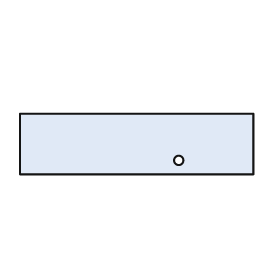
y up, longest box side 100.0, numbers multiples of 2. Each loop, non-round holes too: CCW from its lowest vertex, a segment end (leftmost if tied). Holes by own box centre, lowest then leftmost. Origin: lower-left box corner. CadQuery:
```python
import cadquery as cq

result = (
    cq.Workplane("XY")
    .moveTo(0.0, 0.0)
    .lineTo(100.0, 0.0)
    .lineTo(100.0, 26.0)
    .lineTo(0.0, 26.0)
    .close()
    .moveTo(68.0, 6.0)
    .circle(2.0)
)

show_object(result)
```